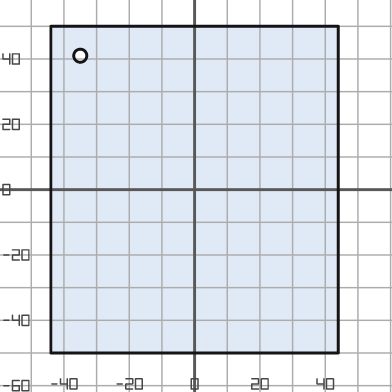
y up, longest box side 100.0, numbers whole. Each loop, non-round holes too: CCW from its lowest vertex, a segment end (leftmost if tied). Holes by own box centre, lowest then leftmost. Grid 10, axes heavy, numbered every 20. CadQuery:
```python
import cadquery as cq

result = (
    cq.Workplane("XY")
    .moveTo(-44.0, -50.0)
    .lineTo(44.0, -50.0)
    .lineTo(44.0, 50.0)
    .lineTo(-44.0, 50.0)
    .close()
    .moveTo(-35.0, 41.0)
    .circle(2.0)
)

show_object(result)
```